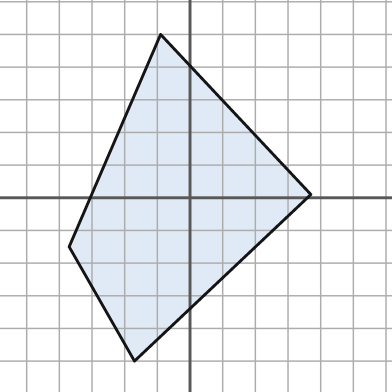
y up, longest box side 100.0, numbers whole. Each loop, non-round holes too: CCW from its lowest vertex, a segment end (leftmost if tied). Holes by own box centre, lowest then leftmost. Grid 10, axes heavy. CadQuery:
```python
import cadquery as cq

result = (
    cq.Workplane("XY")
    .moveTo(-17.0, -50.0)
    .lineTo(37.0, 1.0)
    .lineTo(-9.0, 50.0)
    .lineTo(-37.0, -15.0)
    .close()
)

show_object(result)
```